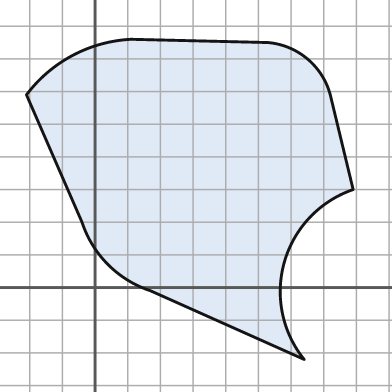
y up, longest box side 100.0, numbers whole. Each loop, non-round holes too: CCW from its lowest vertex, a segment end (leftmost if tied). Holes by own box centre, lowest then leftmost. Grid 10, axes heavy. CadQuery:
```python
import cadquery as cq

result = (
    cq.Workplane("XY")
    .moveTo(64.0, -22.0)
    .threePointArc((58.0, 8.0), (79.0, 30.0))
    .lineTo(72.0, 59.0)
    .threePointArc((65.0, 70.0), (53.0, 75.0))
    .lineTo(11.0, 76.0)
    .threePointArc((-7.0, 71.0), (-21.0, 59.0))
    .lineTo(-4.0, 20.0)
    .threePointArc((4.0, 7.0), (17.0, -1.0))
    .close()
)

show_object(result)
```